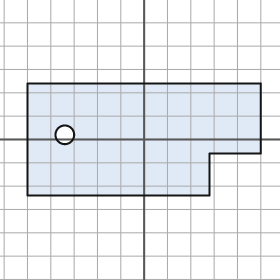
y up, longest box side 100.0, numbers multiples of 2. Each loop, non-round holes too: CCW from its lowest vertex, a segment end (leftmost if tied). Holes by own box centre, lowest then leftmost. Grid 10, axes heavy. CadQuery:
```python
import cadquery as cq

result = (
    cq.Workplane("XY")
    .moveTo(-50.0, -24.0)
    .lineTo(28.0, -24.0)
    .lineTo(28.0, -6.0)
    .lineTo(50.0, -6.0)
    .lineTo(50.0, 24.0)
    .lineTo(-50.0, 24.0)
    .close()
    .moveTo(-34.0, 2.0)
    .circle(4.0)
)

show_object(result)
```